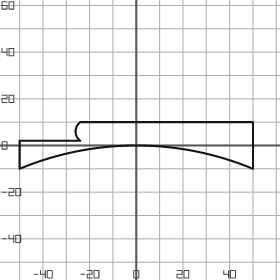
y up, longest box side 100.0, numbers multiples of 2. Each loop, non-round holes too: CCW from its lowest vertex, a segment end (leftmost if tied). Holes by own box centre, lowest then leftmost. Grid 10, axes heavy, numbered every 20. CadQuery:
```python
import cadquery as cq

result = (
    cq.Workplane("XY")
    .moveTo(-50.0, -10.0)
    .threePointArc((0.0, 0.0), (50.0, -10.0))
    .lineTo(50.0, 10.0)
    .lineTo(-24.0, 10.0)
    .threePointArc((-26.0, 6.0), (-24.0, 2.0))
    .lineTo(-50.0, 2.0)
    .close()
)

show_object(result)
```